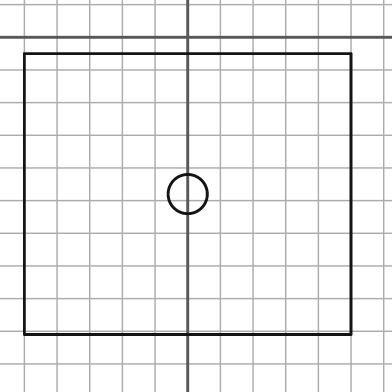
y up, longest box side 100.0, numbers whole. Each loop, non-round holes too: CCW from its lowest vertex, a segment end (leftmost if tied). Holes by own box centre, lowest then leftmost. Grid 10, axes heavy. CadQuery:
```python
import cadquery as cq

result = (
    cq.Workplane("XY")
    .moveTo(-50.0, -91.0)
    .lineTo(50.0, -91.0)
    .lineTo(50.0, -5.0)
    .lineTo(-50.0, -5.0)
    .close()
    .moveTo(0.0, -48.0)
    .circle(6.0)
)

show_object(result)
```